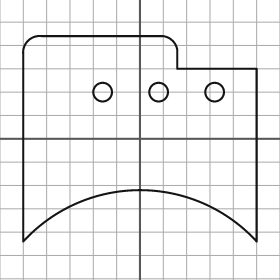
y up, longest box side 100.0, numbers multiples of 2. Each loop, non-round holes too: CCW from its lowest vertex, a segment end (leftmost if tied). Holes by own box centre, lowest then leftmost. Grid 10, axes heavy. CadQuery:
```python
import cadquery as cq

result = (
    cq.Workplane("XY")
    .moveTo(-50.0, -44.0)
    .threePointArc((0.0, -22.0), (50.0, -44.0))
    .lineTo(50.0, 30.0)
    .lineTo(16.0, 30.0)
    .lineTo(16.0, 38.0)
    .threePointArc((14.0, 42.0), (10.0, 44.0))
    .lineTo(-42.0, 44.0)
    .threePointArc((-48.0, 42.0), (-50.0, 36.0))
    .close()
    .moveTo(-16.0, 20.0)
    .circle(4.0)
    .moveTo(8.0, 20.0)
    .circle(4.0)
    .moveTo(32.0, 20.0)
    .circle(4.0)
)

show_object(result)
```